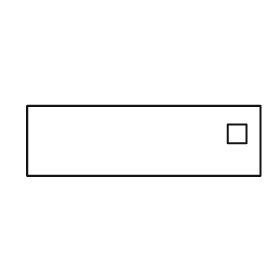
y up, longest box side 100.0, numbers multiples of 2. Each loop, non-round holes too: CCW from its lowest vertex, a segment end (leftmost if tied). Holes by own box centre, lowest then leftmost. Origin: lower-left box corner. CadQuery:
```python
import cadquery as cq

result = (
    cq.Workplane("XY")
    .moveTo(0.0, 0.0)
    .lineTo(100.0, 0.0)
    .lineTo(100.0, 30.0)
    .lineTo(0.0, 30.0)
    .close()
    .moveTo(86.0, 14.0)
    .lineTo(94.0, 14.0)
    .lineTo(94.0, 22.0)
    .lineTo(86.0, 22.0)
    .close()
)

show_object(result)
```